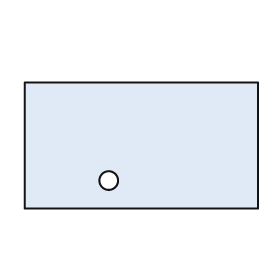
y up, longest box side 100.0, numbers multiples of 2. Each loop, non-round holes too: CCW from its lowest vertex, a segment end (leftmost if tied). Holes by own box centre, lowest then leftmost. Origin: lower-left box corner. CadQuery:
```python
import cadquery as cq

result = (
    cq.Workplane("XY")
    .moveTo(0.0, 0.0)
    .lineTo(100.0, 0.0)
    .lineTo(100.0, 54.0)
    .lineTo(0.0, 54.0)
    .close()
    .moveTo(36.0, 12.0)
    .circle(4.0)
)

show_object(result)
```